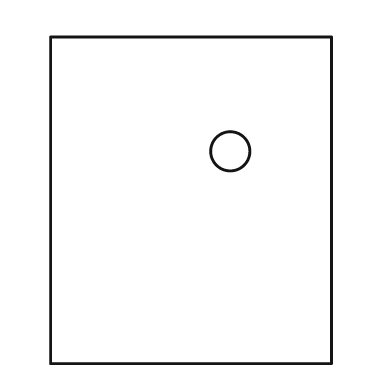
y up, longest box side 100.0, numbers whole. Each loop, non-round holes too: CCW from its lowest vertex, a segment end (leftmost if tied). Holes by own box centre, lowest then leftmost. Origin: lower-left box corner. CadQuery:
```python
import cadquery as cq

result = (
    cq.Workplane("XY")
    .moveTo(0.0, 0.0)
    .lineTo(86.0, 0.0)
    .lineTo(86.0, 100.0)
    .lineTo(0.0, 100.0)
    .close()
    .moveTo(55.0, 65.0)
    .circle(6.0)
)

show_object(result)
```